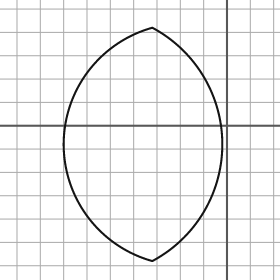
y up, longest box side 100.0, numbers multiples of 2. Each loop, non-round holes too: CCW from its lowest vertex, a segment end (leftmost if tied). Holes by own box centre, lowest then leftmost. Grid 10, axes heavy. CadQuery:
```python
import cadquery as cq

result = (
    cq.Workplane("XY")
    .moveTo(-32.0, -58.0)
    .threePointArc((-2.0, -8.0), (-32.0, 42.0))
    .threePointArc((-70.0, -8.0), (-32.0, -58.0))
    .close()
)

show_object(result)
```